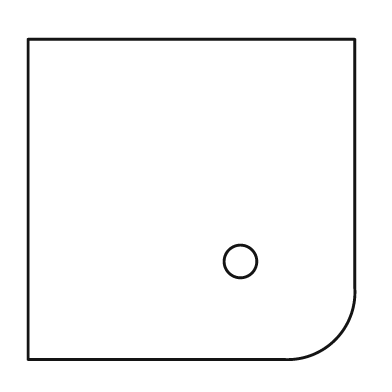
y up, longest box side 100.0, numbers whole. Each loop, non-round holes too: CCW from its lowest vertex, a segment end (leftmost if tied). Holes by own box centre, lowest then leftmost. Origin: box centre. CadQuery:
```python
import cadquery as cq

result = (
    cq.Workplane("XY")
    .moveTo(-50.0, -49.0)
    .lineTo(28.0, -49.0)
    .threePointArc((44.0, -43.0), (50.0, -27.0))
    .lineTo(50.0, 49.0)
    .lineTo(-50.0, 49.0)
    .close()
    .moveTo(15.0, -19.0)
    .circle(5.0)
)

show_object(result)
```